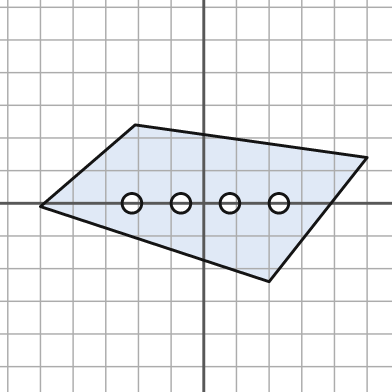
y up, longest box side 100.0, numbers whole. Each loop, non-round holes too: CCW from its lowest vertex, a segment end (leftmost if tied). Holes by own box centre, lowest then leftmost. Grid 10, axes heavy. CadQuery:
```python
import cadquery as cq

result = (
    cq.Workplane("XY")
    .moveTo(20.0, -24.0)
    .lineTo(50.0, 14.0)
    .lineTo(-21.0, 24.0)
    .lineTo(-50.0, -1.0)
    .close()
    .moveTo(-22.0, 0.0)
    .circle(3.0)
    .moveTo(-7.0, 0.0)
    .circle(3.0)
    .moveTo(8.0, 0.0)
    .circle(3.0)
    .moveTo(23.0, 0.0)
    .circle(3.0)
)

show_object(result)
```